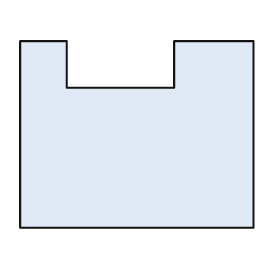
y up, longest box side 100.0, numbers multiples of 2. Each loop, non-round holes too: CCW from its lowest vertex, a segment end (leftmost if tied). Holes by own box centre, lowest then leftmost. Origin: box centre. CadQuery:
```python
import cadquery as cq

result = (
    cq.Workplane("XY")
    .moveTo(-50.0, -40.0)
    .lineTo(50.0, -40.0)
    .lineTo(50.0, 40.0)
    .lineTo(16.0, 40.0)
    .lineTo(16.0, 20.0)
    .lineTo(-30.0, 20.0)
    .lineTo(-30.0, 40.0)
    .lineTo(-50.0, 40.0)
    .close()
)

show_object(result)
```